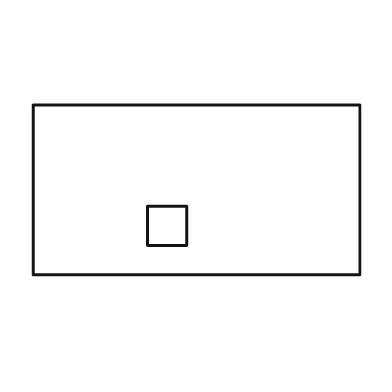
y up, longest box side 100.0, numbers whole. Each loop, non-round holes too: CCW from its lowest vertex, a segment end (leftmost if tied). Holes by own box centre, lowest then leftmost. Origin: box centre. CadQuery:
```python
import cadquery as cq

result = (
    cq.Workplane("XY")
    .moveTo(-50.0, -26.0)
    .lineTo(50.0, -26.0)
    .lineTo(50.0, 26.0)
    .lineTo(-50.0, 26.0)
    .close()
    .moveTo(-15.0, -17.0)
    .lineTo(-3.0, -17.0)
    .lineTo(-3.0, -5.0)
    .lineTo(-15.0, -5.0)
    .close()
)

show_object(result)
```